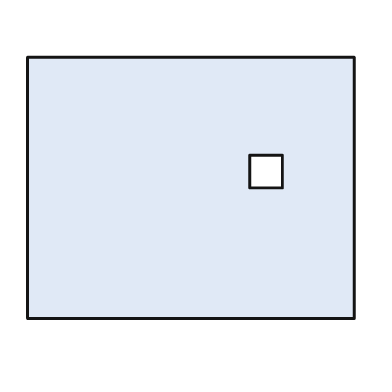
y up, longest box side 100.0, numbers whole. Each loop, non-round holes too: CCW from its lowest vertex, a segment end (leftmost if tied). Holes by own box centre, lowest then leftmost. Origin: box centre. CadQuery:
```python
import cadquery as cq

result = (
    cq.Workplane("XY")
    .moveTo(-50.0, -40.0)
    .lineTo(50.0, -40.0)
    .lineTo(50.0, 40.0)
    .lineTo(-50.0, 40.0)
    .close()
    .moveTo(18.0, 0.0)
    .lineTo(28.0, 0.0)
    .lineTo(28.0, 10.0)
    .lineTo(18.0, 10.0)
    .close()
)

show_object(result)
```